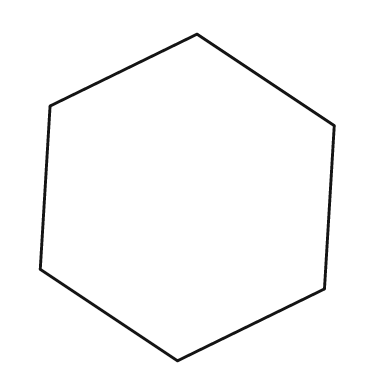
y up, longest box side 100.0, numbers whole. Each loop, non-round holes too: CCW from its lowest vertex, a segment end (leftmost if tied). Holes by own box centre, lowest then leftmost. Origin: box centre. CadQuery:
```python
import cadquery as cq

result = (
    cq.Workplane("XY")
    .moveTo(-3.0, -50.0)
    .lineTo(42.0, -28.0)
    .lineTo(45.0, 22.0)
    .lineTo(3.0, 50.0)
    .lineTo(-42.0, 28.0)
    .lineTo(-45.0, -22.0)
    .close()
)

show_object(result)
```